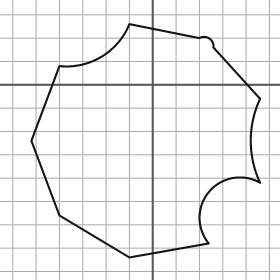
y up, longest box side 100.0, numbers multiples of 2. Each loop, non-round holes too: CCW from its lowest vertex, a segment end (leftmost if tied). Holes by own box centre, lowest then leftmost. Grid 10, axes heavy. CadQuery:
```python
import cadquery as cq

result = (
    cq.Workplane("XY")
    .moveTo(-10.0, -74.0)
    .lineTo(24.0, -68.0)
    .threePointArc((24.0, -46.0), (46.0, -42.0))
    .threePointArc((42.0, -24.0), (46.0, -6.0))
    .lineTo(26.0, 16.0)
    .threePointArc((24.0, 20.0), (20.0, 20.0))
    .lineTo(-10.0, 26.0)
    .threePointArc((-22.0, 12.0), (-40.0, 8.0))
    .lineTo(-52.0, -24.0)
    .lineTo(-40.0, -56.0)
    .close()
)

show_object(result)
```